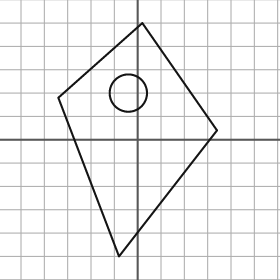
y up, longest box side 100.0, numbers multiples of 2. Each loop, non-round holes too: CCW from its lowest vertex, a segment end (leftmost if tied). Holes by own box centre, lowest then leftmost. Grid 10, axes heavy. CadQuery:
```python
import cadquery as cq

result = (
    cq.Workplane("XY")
    .moveTo(-8.0, -50.0)
    .lineTo(34.0, 4.0)
    .lineTo(2.0, 50.0)
    .lineTo(-34.0, 18.0)
    .close()
    .moveTo(-4.0, 20.0)
    .circle(8.0)
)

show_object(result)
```